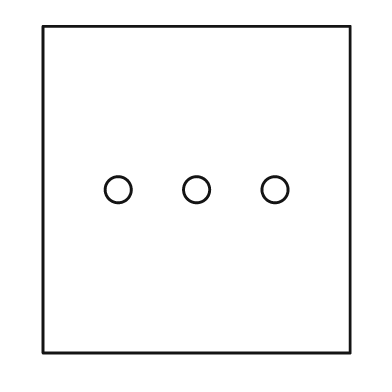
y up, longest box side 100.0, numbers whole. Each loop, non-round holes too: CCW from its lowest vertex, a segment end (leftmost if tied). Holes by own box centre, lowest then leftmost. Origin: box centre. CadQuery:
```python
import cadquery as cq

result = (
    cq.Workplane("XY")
    .moveTo(-47.0, -50.0)
    .lineTo(47.0, -50.0)
    .lineTo(47.0, 50.0)
    .lineTo(-47.0, 50.0)
    .close()
    .moveTo(-24.0, 0.0)
    .circle(4.0)
    .moveTo(0.0, 0.0)
    .circle(4.0)
    .moveTo(24.0, 0.0)
    .circle(4.0)
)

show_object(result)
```